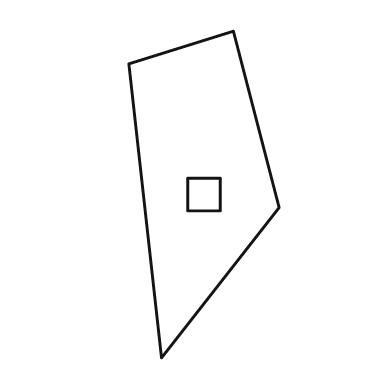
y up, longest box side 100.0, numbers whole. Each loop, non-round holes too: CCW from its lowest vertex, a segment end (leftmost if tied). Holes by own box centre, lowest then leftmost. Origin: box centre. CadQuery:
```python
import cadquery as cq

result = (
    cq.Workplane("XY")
    .moveTo(-13.0, -50.0)
    .lineTo(23.0, -4.0)
    .lineTo(9.0, 50.0)
    .lineTo(-23.0, 40.0)
    .close()
    .moveTo(-5.0, -5.0)
    .lineTo(5.0, -5.0)
    .lineTo(5.0, 5.0)
    .lineTo(-5.0, 5.0)
    .close()
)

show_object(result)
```